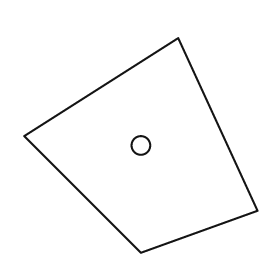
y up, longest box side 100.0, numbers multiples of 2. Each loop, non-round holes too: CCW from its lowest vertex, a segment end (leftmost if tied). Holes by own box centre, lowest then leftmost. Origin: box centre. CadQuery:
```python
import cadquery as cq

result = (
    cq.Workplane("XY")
    .moveTo(0.0, -46.0)
    .lineTo(50.0, -28.0)
    .lineTo(16.0, 46.0)
    .lineTo(-50.0, 4.0)
    .close()
    .moveTo(0.0, 0.0)
    .circle(4.0)
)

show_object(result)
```